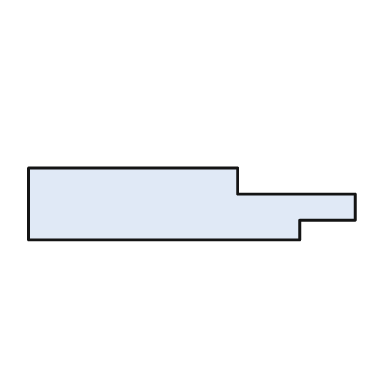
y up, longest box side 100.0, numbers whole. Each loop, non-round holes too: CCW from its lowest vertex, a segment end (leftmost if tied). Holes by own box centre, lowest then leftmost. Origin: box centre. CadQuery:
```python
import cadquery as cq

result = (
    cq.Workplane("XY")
    .moveTo(-50.0, -11.0)
    .lineTo(33.0, -11.0)
    .lineTo(33.0, -5.0)
    .lineTo(50.0, -5.0)
    .lineTo(50.0, 3.0)
    .lineTo(14.0, 3.0)
    .lineTo(14.0, 11.0)
    .lineTo(-50.0, 11.0)
    .close()
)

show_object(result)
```